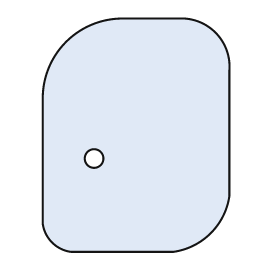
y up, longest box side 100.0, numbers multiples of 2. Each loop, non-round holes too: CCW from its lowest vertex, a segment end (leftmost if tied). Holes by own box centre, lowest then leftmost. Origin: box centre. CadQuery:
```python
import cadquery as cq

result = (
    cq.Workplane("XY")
    .moveTo(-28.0, -50.0)
    .lineTo(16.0, -50.0)
    .threePointArc((32.0, -42.0), (40.0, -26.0))
    .lineTo(40.0, 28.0)
    .threePointArc((34.0, 44.0), (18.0, 50.0))
    .lineTo(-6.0, 50.0)
    .threePointArc((-30.0, 40.0), (-40.0, 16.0))
    .lineTo(-40.0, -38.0)
    .threePointArc((-36.0, -46.0), (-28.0, -50.0))
    .close()
    .moveTo(-18.0, -10.0)
    .circle(4.0)
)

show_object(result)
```